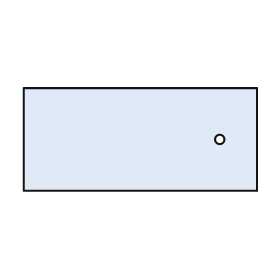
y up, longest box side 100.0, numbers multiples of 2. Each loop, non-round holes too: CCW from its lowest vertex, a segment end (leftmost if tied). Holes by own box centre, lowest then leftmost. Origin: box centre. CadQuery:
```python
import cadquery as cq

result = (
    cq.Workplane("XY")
    .moveTo(-50.0, -22.0)
    .lineTo(50.0, -22.0)
    .lineTo(50.0, 22.0)
    .lineTo(-50.0, 22.0)
    .close()
    .moveTo(34.0, 0.0)
    .circle(2.0)
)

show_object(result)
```